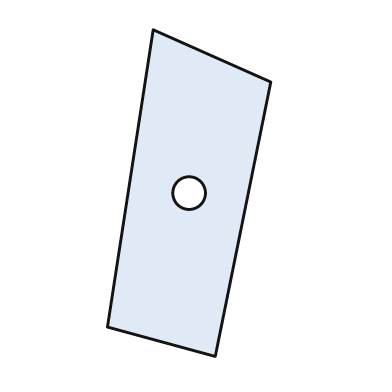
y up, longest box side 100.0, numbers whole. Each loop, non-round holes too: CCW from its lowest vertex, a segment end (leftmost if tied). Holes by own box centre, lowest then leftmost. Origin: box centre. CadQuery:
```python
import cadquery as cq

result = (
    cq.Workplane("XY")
    .moveTo(8.0, -50.0)
    .lineTo(25.0, 34.0)
    .lineTo(-11.0, 50.0)
    .lineTo(-25.0, -41.0)
    .close()
    .moveTo(0.0, 0.0)
    .circle(5.0)
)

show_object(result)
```